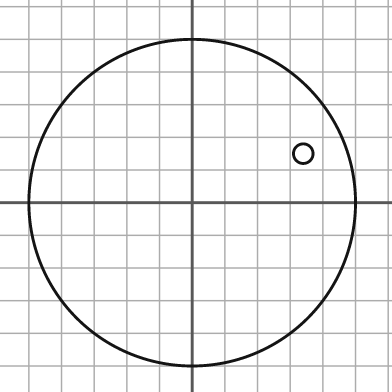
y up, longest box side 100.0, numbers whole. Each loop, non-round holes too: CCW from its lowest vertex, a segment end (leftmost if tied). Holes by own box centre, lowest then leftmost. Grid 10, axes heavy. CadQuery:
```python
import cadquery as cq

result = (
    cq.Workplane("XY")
    .moveTo(0.0, 0.0)
    .circle(50.0)
    .moveTo(34.0, 15.0)
    .circle(3.0)
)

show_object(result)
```